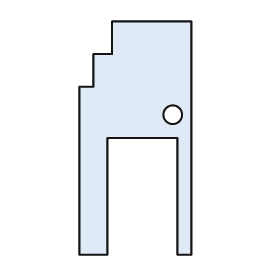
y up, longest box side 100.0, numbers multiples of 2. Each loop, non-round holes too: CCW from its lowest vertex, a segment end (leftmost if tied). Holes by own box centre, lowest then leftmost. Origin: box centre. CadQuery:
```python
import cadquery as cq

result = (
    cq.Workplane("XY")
    .moveTo(-24.0, -50.0)
    .lineTo(-12.0, -50.0)
    .lineTo(-12.0, 0.0)
    .lineTo(18.0, 0.0)
    .lineTo(18.0, -50.0)
    .lineTo(24.0, -50.0)
    .lineTo(24.0, 50.0)
    .lineTo(-10.0, 50.0)
    .lineTo(-10.0, 36.0)
    .lineTo(-18.0, 36.0)
    .lineTo(-18.0, 22.0)
    .lineTo(-24.0, 22.0)
    .close()
    .moveTo(16.0, 10.0)
    .circle(4.0)
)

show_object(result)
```